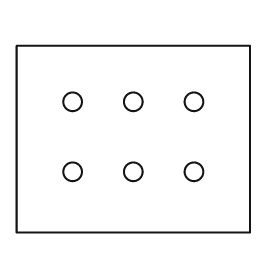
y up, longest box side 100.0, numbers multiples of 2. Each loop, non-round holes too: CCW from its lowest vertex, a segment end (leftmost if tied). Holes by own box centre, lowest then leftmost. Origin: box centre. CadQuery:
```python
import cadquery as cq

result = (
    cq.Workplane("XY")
    .moveTo(-50.0, -40.0)
    .lineTo(50.0, -40.0)
    .lineTo(50.0, 40.0)
    .lineTo(-50.0, 40.0)
    .close()
    .moveTo(-26.0, -14.0)
    .circle(4.0)
    .moveTo(0.0, -14.0)
    .circle(4.0)
    .moveTo(26.0, -14.0)
    .circle(4.0)
    .moveTo(-26.0, 16.0)
    .circle(4.0)
    .moveTo(0.0, 16.0)
    .circle(4.0)
    .moveTo(26.0, 16.0)
    .circle(4.0)
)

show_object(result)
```